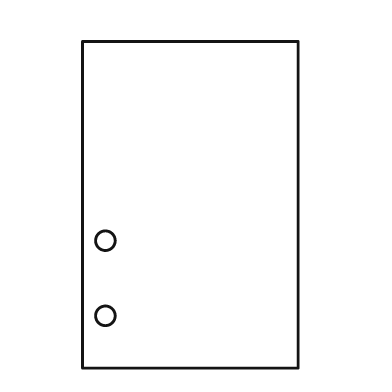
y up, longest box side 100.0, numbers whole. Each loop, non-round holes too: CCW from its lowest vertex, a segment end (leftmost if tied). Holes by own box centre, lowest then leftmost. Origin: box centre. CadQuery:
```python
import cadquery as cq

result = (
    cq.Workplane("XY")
    .moveTo(-33.0, -50.0)
    .lineTo(33.0, -50.0)
    .lineTo(33.0, 50.0)
    .lineTo(-33.0, 50.0)
    .close()
    .moveTo(-26.0, -34.0)
    .circle(3.0)
    .moveTo(-26.0, -11.0)
    .circle(3.0)
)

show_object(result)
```